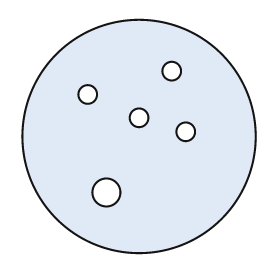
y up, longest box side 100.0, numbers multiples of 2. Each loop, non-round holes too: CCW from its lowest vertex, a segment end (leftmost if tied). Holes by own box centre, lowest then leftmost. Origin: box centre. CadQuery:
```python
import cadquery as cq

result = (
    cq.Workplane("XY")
    .moveTo(0.0, 0.0)
    .circle(50.0)
    .moveTo(-14.0, -24.0)
    .circle(6.0)
    .moveTo(20.0, 2.0)
    .circle(4.0)
    .moveTo(0.0, 8.0)
    .circle(4.0)
    .moveTo(-22.0, 18.0)
    .circle(4.0)
    .moveTo(14.0, 28.0)
    .circle(4.0)
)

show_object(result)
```